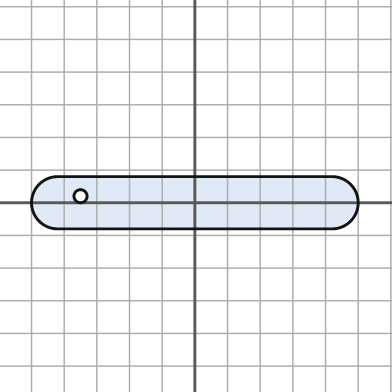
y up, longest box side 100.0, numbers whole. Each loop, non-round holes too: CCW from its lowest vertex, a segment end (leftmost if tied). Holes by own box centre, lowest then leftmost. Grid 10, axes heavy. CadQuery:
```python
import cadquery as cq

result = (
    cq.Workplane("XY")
    .moveTo(-42.0, -8.0)
    .lineTo(42.0, -8.0)
    .threePointArc((50.0, 0.0), (42.0, 8.0))
    .lineTo(-42.0, 8.0)
    .threePointArc((-50.0, 0.0), (-42.0, -8.0))
    .close()
    .moveTo(-35.0, 2.0)
    .circle(2.0)
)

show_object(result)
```